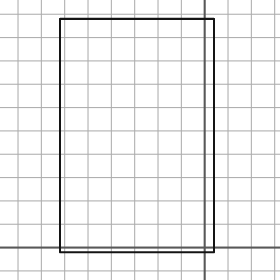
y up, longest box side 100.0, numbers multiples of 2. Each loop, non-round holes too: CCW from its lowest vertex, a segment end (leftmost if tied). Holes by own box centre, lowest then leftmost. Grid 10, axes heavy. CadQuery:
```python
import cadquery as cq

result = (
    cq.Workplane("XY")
    .moveTo(-62.0, -2.0)
    .lineTo(4.0, -2.0)
    .lineTo(4.0, 98.0)
    .lineTo(-62.0, 98.0)
    .close()
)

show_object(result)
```